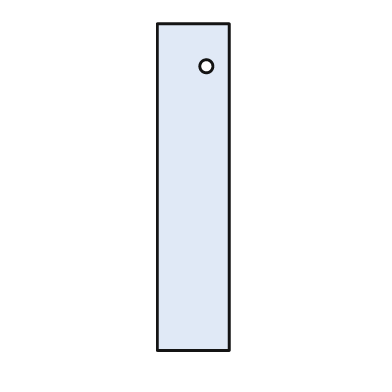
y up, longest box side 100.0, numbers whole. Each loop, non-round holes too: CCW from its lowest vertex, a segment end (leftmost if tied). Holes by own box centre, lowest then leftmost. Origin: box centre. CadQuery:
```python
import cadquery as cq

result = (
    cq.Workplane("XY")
    .moveTo(-11.0, -50.0)
    .lineTo(11.0, -50.0)
    .lineTo(11.0, 50.0)
    .lineTo(-11.0, 50.0)
    .close()
    .moveTo(4.0, 37.0)
    .circle(2.0)
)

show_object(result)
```